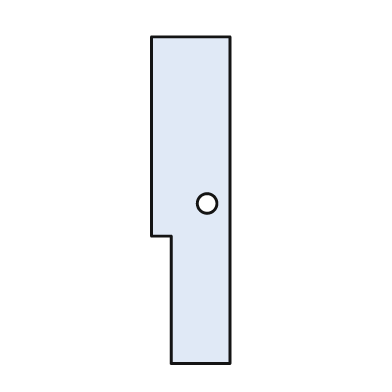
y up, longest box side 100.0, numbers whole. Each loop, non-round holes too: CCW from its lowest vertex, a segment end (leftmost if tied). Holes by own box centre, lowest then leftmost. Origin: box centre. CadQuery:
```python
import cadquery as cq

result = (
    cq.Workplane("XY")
    .moveTo(-6.0, -50.0)
    .lineTo(12.0, -50.0)
    .lineTo(12.0, 50.0)
    .lineTo(-12.0, 50.0)
    .lineTo(-12.0, -11.0)
    .lineTo(-6.0, -11.0)
    .close()
    .moveTo(5.0, -1.0)
    .circle(3.0)
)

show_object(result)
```